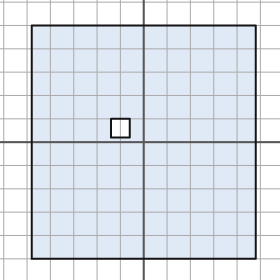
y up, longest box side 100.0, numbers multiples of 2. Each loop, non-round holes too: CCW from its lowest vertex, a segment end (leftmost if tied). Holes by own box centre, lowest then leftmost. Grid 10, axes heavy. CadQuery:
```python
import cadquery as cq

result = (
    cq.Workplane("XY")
    .moveTo(-48.0, -50.0)
    .lineTo(48.0, -50.0)
    .lineTo(48.0, 50.0)
    .lineTo(-48.0, 50.0)
    .close()
    .moveTo(-14.0, 2.0)
    .lineTo(-6.0, 2.0)
    .lineTo(-6.0, 10.0)
    .lineTo(-14.0, 10.0)
    .close()
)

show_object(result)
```